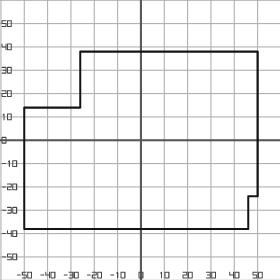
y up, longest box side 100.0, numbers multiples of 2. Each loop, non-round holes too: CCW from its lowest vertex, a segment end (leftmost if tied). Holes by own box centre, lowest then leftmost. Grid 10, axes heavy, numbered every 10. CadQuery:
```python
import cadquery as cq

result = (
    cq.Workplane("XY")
    .moveTo(-50.0, -38.0)
    .lineTo(46.0, -38.0)
    .lineTo(46.0, -24.0)
    .lineTo(50.0, -24.0)
    .lineTo(50.0, 38.0)
    .lineTo(-26.0, 38.0)
    .lineTo(-26.0, 14.0)
    .lineTo(-50.0, 14.0)
    .close()
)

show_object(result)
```